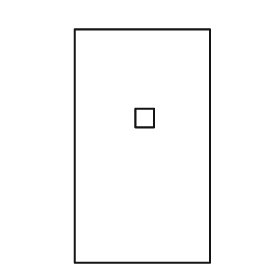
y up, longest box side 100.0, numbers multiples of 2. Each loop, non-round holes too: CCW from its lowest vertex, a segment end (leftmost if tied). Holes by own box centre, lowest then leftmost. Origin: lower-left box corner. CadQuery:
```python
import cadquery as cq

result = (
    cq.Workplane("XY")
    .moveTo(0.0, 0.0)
    .lineTo(58.0, 0.0)
    .lineTo(58.0, 100.0)
    .lineTo(0.0, 100.0)
    .close()
    .moveTo(26.0, 58.0)
    .lineTo(34.0, 58.0)
    .lineTo(34.0, 66.0)
    .lineTo(26.0, 66.0)
    .close()
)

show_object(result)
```